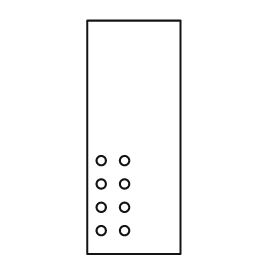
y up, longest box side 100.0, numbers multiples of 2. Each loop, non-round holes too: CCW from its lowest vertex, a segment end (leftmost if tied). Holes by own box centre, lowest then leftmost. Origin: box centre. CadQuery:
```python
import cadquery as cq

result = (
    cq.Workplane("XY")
    .moveTo(-20.0, -50.0)
    .lineTo(20.0, -50.0)
    .lineTo(20.0, 50.0)
    .lineTo(-20.0, 50.0)
    .close()
    .moveTo(-14.0, -40.0)
    .circle(2.0)
    .moveTo(-4.0, -40.0)
    .circle(2.0)
    .moveTo(-14.0, -30.0)
    .circle(2.0)
    .moveTo(-4.0, -30.0)
    .circle(2.0)
    .moveTo(-14.0, -20.0)
    .circle(2.0)
    .moveTo(-4.0, -20.0)
    .circle(2.0)
    .moveTo(-14.0, -10.0)
    .circle(2.0)
    .moveTo(-4.0, -10.0)
    .circle(2.0)
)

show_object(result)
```